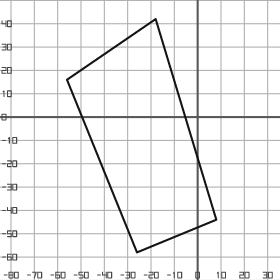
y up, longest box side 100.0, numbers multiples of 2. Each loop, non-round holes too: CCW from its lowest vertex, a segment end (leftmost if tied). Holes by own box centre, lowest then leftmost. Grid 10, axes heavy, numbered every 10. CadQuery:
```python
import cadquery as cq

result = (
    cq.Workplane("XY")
    .moveTo(-26.0, -58.0)
    .lineTo(8.0, -44.0)
    .lineTo(-18.0, 42.0)
    .lineTo(-56.0, 16.0)
    .close()
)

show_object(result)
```